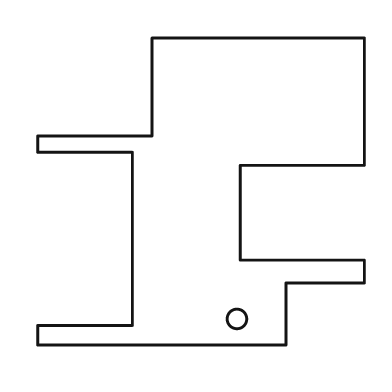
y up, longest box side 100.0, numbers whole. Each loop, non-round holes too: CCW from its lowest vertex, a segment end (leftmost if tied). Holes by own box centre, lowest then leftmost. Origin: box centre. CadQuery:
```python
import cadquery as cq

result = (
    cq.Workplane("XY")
    .moveTo(-50.0, -47.0)
    .lineTo(26.0, -47.0)
    .lineTo(26.0, -28.0)
    .lineTo(50.0, -28.0)
    .lineTo(50.0, -21.0)
    .lineTo(12.0, -21.0)
    .lineTo(12.0, 8.0)
    .lineTo(50.0, 8.0)
    .lineTo(50.0, 47.0)
    .lineTo(-15.0, 47.0)
    .lineTo(-15.0, 17.0)
    .lineTo(-50.0, 17.0)
    .lineTo(-50.0, 12.0)
    .lineTo(-21.0, 12.0)
    .lineTo(-21.0, -41.0)
    .lineTo(-50.0, -41.0)
    .close()
    .moveTo(11.0, -39.0)
    .circle(3.0)
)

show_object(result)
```